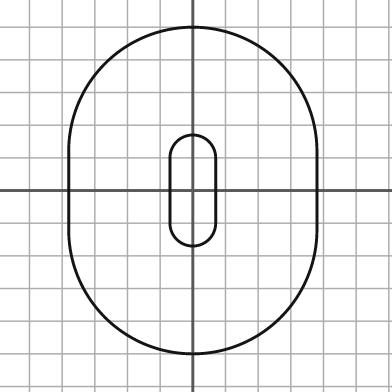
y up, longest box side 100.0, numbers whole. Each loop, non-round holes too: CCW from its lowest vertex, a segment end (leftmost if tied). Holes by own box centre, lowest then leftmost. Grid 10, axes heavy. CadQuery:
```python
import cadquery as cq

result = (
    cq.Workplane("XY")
    .moveTo(-38.0, -12.0)
    .threePointArc((0.0, -50.0), (38.0, -12.0))
    .lineTo(38.0, 12.0)
    .threePointArc((0.0, 50.0), (-38.0, 12.0))
    .close()
    .moveTo(-7.0, -10.0)
    .threePointArc((0.0, -17.0), (7.0, -10.0))
    .lineTo(7.0, 10.0)
    .threePointArc((0.0, 17.0), (-7.0, 10.0))
    .close()
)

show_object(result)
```